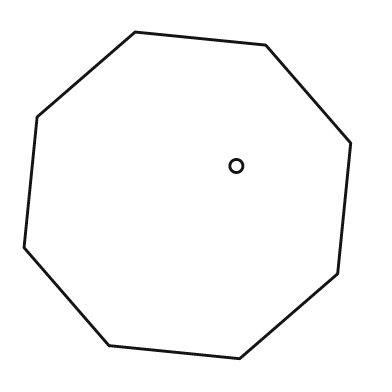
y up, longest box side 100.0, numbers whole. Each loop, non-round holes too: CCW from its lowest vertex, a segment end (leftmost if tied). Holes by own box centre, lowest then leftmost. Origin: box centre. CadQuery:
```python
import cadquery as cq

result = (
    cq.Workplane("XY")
    .moveTo(16.0, -50.0)
    .lineTo(46.0, -24.0)
    .lineTo(50.0, 16.0)
    .lineTo(24.0, 46.0)
    .lineTo(-16.0, 50.0)
    .lineTo(-46.0, 24.0)
    .lineTo(-50.0, -16.0)
    .lineTo(-24.0, -46.0)
    .close()
    .moveTo(15.0, 9.0)
    .circle(2.0)
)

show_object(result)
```